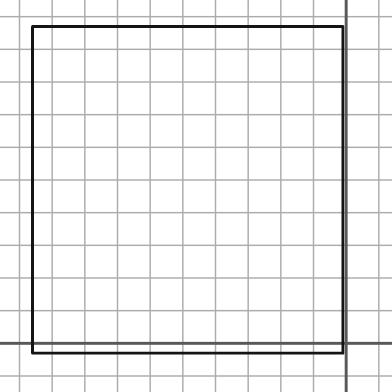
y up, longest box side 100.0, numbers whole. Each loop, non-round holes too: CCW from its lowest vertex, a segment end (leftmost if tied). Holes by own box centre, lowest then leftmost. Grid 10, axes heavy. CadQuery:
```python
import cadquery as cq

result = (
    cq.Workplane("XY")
    .moveTo(-96.0, -3.0)
    .lineTo(-1.0, -3.0)
    .lineTo(-1.0, 97.0)
    .lineTo(-96.0, 97.0)
    .close()
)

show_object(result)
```